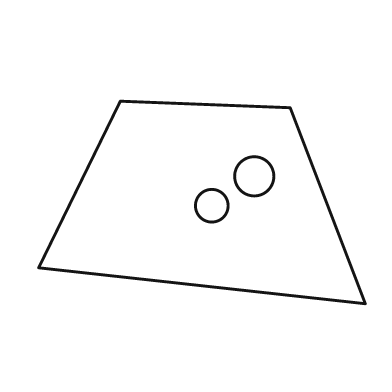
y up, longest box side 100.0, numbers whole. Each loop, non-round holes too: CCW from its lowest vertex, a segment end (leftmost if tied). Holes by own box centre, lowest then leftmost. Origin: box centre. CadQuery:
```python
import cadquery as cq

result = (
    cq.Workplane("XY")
    .moveTo(50.0, -31.0)
    .lineTo(27.0, 29.0)
    .lineTo(-25.0, 31.0)
    .lineTo(-50.0, -20.0)
    .close()
    .moveTo(3.0, -1.0)
    .circle(5.0)
    .moveTo(16.0, 8.0)
    .circle(6.0)
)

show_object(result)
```